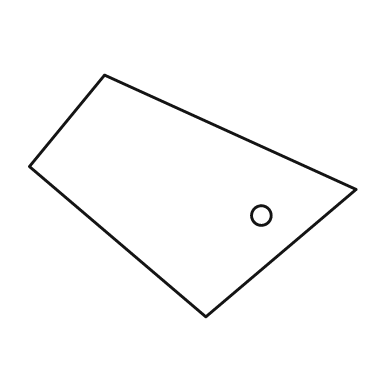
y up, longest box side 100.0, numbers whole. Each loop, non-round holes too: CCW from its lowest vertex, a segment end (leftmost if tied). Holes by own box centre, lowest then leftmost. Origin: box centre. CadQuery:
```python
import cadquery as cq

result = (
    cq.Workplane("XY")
    .moveTo(4.0, -37.0)
    .lineTo(50.0, 2.0)
    .lineTo(-27.0, 37.0)
    .lineTo(-50.0, 9.0)
    .close()
    .moveTo(21.0, -6.0)
    .circle(3.0)
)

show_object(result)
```